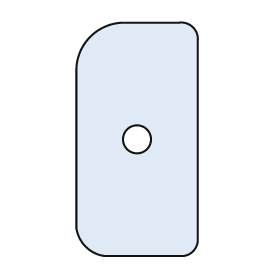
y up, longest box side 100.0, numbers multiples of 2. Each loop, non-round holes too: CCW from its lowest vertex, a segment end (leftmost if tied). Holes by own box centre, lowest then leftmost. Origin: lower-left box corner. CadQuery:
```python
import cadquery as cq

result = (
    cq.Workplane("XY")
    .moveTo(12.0, 0.0)
    .lineTo(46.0, 0.0)
    .threePointArc((50.0, 2.0), (52.0, 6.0))
    .lineTo(52.0, 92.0)
    .threePointArc((50.0, 98.0), (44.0, 100.0))
    .lineTo(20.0, 100.0)
    .threePointArc((6.0, 94.0), (0.0, 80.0))
    .lineTo(0.0, 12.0)
    .threePointArc((4.0, 4.0), (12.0, 0.0))
    .close()
    .moveTo(26.0, 50.0)
    .circle(6.0)
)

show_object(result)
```